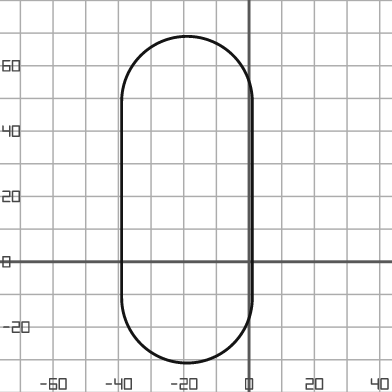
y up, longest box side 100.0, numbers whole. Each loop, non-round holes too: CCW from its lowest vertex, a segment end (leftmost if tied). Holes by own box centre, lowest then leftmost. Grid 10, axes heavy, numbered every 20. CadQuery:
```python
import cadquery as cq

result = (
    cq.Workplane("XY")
    .moveTo(-39.0, -11.0)
    .threePointArc((-19.0, -31.0), (1.0, -11.0))
    .lineTo(1.0, 49.0)
    .threePointArc((-19.0, 69.0), (-39.0, 49.0))
    .close()
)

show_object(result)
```